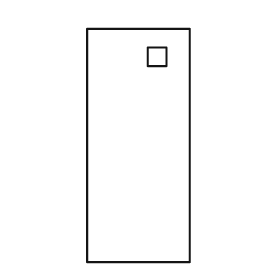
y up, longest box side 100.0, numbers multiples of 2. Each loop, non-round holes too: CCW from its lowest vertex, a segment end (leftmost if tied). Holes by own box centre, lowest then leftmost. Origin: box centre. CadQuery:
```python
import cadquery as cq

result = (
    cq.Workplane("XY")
    .moveTo(-22.0, -50.0)
    .lineTo(22.0, -50.0)
    .lineTo(22.0, 50.0)
    .lineTo(-22.0, 50.0)
    .close()
    .moveTo(4.0, 34.0)
    .lineTo(12.0, 34.0)
    .lineTo(12.0, 42.0)
    .lineTo(4.0, 42.0)
    .close()
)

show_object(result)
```